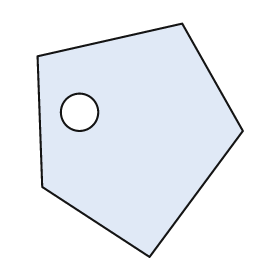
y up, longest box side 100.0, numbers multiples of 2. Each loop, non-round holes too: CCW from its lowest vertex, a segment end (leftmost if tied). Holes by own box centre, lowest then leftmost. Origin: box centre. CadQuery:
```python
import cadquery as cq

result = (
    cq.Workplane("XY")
    .moveTo(4.0, -50.0)
    .lineTo(44.0, 4.0)
    .lineTo(18.0, 50.0)
    .lineTo(-44.0, 36.0)
    .lineTo(-42.0, -20.0)
    .close()
    .moveTo(-26.0, 12.0)
    .circle(8.0)
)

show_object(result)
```